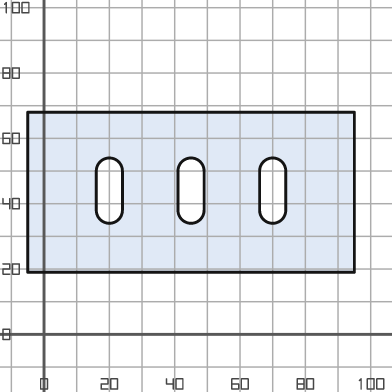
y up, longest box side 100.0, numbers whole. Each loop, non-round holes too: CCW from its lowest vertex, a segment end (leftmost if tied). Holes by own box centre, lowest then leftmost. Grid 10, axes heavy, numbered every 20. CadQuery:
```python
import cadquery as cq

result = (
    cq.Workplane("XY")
    .moveTo(-5.0, 19.0)
    .lineTo(95.0, 19.0)
    .lineTo(95.0, 68.0)
    .lineTo(-5.0, 68.0)
    .close()
    .moveTo(16.0, 38.0)
    .threePointArc((20.0, 34.0), (24.0, 38.0))
    .lineTo(24.0, 50.0)
    .threePointArc((20.0, 54.0), (16.0, 50.0))
    .close()
    .moveTo(41.0, 38.0)
    .threePointArc((45.0, 34.0), (49.0, 38.0))
    .lineTo(49.0, 50.0)
    .threePointArc((45.0, 54.0), (41.0, 50.0))
    .close()
    .moveTo(66.0, 38.0)
    .threePointArc((70.0, 34.0), (74.0, 38.0))
    .lineTo(74.0, 50.0)
    .threePointArc((70.0, 54.0), (66.0, 50.0))
    .close()
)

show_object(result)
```